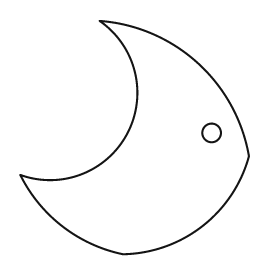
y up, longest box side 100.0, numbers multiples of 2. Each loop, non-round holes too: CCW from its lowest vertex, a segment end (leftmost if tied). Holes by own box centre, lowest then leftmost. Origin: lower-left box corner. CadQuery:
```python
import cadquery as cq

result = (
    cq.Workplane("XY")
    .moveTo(44.0, 0.0)
    .threePointArc((78.0, 12.0), (98.0, 42.0))
    .threePointArc((76.0, 82.0), (34.0, 100.0))
    .threePointArc((46.0, 52.0), (0.0, 34.0))
    .threePointArc((18.0, 12.0), (44.0, 0.0))
    .close()
    .moveTo(82.0, 52.0)
    .circle(4.0)
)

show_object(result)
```